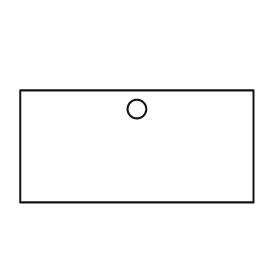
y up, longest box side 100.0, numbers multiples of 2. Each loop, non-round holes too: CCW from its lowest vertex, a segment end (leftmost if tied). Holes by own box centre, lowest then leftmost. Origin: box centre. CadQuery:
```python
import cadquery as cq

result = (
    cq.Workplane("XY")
    .moveTo(-50.0, -24.0)
    .lineTo(50.0, -24.0)
    .lineTo(50.0, 24.0)
    .lineTo(-50.0, 24.0)
    .close()
    .moveTo(0.0, 16.0)
    .circle(4.0)
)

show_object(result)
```